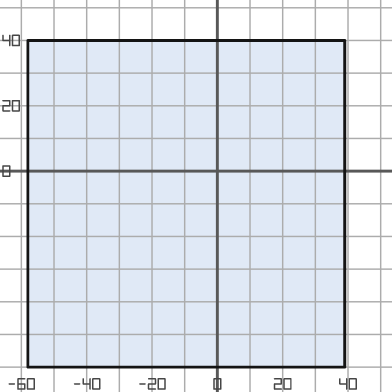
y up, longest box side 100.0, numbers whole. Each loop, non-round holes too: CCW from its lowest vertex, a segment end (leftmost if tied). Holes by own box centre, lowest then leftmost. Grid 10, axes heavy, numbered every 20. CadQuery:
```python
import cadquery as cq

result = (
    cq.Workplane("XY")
    .moveTo(-58.0, -60.0)
    .lineTo(39.0, -60.0)
    .lineTo(39.0, 40.0)
    .lineTo(-58.0, 40.0)
    .close()
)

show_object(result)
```